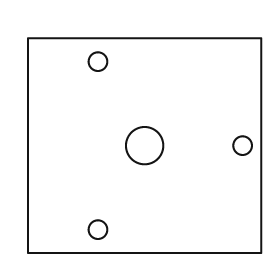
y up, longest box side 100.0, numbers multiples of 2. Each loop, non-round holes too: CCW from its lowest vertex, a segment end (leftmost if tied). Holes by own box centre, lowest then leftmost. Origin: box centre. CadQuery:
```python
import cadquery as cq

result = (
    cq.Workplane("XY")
    .moveTo(-50.0, -46.0)
    .lineTo(50.0, -46.0)
    .lineTo(50.0, 46.0)
    .lineTo(-50.0, 46.0)
    .close()
    .moveTo(-20.0, -36.0)
    .circle(4.0)
    .moveTo(0.0, 0.0)
    .circle(8.0)
    .moveTo(42.0, 0.0)
    .circle(4.0)
    .moveTo(-20.0, 36.0)
    .circle(4.0)
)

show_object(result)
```